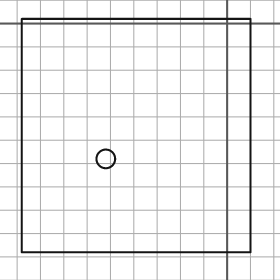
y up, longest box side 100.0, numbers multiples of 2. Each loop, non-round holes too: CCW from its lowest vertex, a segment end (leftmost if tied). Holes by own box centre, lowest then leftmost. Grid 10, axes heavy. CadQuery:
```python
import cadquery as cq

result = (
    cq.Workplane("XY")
    .moveTo(-88.0, -98.0)
    .lineTo(10.0, -98.0)
    .lineTo(10.0, 2.0)
    .lineTo(-88.0, 2.0)
    .close()
    .moveTo(-52.0, -58.0)
    .circle(4.0)
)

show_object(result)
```